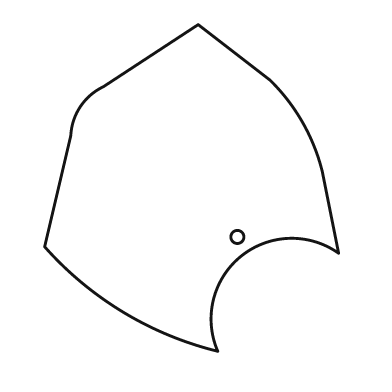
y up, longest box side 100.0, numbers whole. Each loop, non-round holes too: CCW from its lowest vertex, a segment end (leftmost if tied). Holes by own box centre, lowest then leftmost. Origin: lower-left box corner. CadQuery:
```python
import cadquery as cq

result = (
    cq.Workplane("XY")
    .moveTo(53.0, 0.0)
    .threePointArc((60.0, 29.0), (90.0, 30.0))
    .lineTo(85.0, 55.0)
    .threePointArc((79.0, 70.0), (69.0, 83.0))
    .lineTo(47.0, 100.0)
    .lineTo(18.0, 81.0)
    .threePointArc((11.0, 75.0), (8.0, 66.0))
    .lineTo(0.0, 32.0)
    .threePointArc((24.0, 12.0), (53.0, 0.0))
    .close()
    .moveTo(59.0, 35.0)
    .circle(2.0)
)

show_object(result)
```